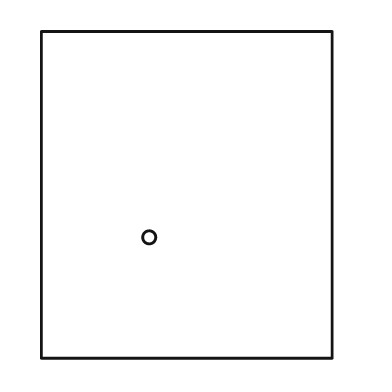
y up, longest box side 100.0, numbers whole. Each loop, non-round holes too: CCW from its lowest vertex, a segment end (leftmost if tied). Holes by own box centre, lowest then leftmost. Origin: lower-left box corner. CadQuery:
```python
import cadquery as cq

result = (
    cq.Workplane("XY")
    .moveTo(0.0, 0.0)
    .lineTo(89.0, 0.0)
    .lineTo(89.0, 100.0)
    .lineTo(0.0, 100.0)
    .close()
    .moveTo(33.0, 37.0)
    .circle(2.0)
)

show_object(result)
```